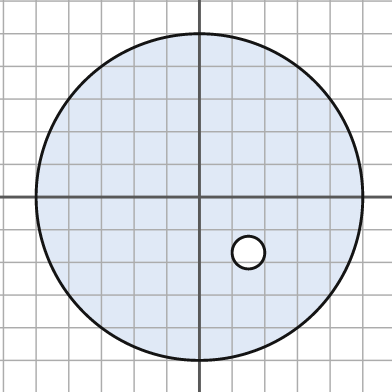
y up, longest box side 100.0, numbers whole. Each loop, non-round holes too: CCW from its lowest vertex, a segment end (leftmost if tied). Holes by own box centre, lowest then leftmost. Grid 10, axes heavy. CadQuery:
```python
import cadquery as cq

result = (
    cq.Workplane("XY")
    .moveTo(0.0, 0.0)
    .circle(50.0)
    .moveTo(15.0, -17.0)
    .circle(5.0)
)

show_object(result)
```